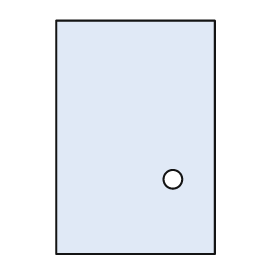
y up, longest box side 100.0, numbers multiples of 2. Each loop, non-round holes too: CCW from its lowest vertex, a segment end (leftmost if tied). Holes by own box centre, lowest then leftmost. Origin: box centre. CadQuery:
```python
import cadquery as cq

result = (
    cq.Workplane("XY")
    .moveTo(-34.0, -50.0)
    .lineTo(34.0, -50.0)
    .lineTo(34.0, 50.0)
    .lineTo(-34.0, 50.0)
    .close()
    .moveTo(16.0, -18.0)
    .circle(4.0)
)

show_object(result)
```